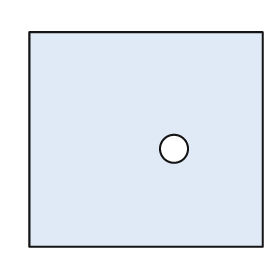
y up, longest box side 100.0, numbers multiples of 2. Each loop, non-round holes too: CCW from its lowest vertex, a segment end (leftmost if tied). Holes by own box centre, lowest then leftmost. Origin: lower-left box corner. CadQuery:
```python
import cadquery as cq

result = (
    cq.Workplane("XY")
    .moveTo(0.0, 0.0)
    .lineTo(100.0, 0.0)
    .lineTo(100.0, 92.0)
    .lineTo(0.0, 92.0)
    .close()
    .moveTo(62.0, 42.0)
    .circle(6.0)
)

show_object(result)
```